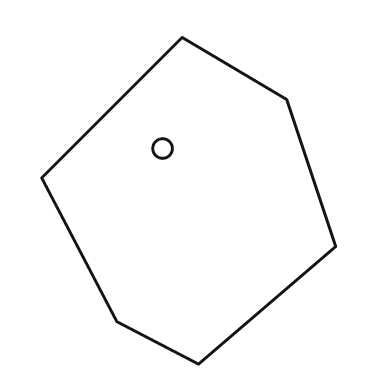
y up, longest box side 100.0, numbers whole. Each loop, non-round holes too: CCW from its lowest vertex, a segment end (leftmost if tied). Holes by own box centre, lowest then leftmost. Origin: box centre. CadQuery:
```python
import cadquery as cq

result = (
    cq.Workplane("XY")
    .moveTo(3.0, -50.0)
    .lineTo(45.0, -14.0)
    .lineTo(30.0, 31.0)
    .lineTo(-2.0, 50.0)
    .lineTo(-45.0, 7.0)
    .lineTo(-22.0, -37.0)
    .close()
    .moveTo(-8.0, 16.0)
    .circle(3.0)
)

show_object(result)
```